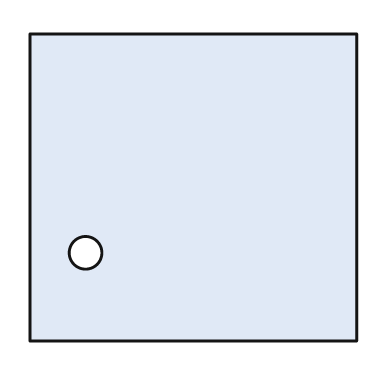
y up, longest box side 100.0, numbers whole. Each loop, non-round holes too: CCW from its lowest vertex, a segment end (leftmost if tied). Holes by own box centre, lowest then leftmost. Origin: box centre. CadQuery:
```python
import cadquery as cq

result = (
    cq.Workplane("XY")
    .moveTo(-50.0, -47.0)
    .lineTo(50.0, -47.0)
    .lineTo(50.0, 47.0)
    .lineTo(-50.0, 47.0)
    .close()
    .moveTo(-33.0, -20.0)
    .circle(5.0)
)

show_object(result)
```